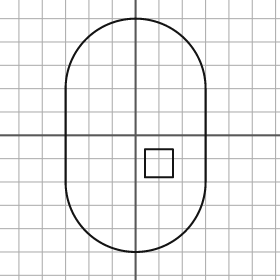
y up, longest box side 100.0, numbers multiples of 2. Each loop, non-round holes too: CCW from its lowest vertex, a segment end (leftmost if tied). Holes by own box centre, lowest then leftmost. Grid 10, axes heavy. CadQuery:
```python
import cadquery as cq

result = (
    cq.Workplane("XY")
    .moveTo(-30.0, -20.0)
    .threePointArc((0.0, -50.0), (30.0, -20.0))
    .lineTo(30.0, 20.0)
    .threePointArc((0.0, 50.0), (-30.0, 20.0))
    .close()
    .moveTo(4.0, -18.0)
    .lineTo(16.0, -18.0)
    .lineTo(16.0, -6.0)
    .lineTo(4.0, -6.0)
    .close()
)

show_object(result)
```